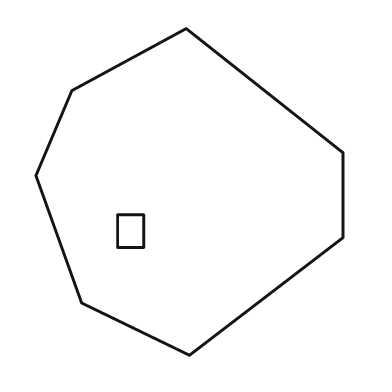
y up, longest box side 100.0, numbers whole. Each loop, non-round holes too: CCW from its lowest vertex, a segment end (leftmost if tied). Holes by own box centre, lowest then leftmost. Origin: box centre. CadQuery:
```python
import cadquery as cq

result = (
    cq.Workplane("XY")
    .moveTo(0.0, -50.0)
    .lineTo(47.0, -14.0)
    .lineTo(47.0, 12.0)
    .lineTo(-1.0, 50.0)
    .lineTo(-36.0, 31.0)
    .lineTo(-47.0, 5.0)
    .lineTo(-33.0, -34.0)
    .close()
    .moveTo(-22.0, -17.0)
    .lineTo(-14.0, -17.0)
    .lineTo(-14.0, -7.0)
    .lineTo(-22.0, -7.0)
    .close()
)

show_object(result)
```